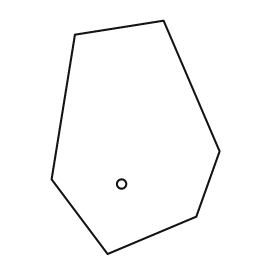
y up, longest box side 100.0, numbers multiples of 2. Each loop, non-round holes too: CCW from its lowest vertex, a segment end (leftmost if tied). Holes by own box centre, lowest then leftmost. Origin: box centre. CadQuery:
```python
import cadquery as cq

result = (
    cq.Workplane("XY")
    .moveTo(-12.0, -50.0)
    .lineTo(26.0, -34.0)
    .lineTo(36.0, -6.0)
    .lineTo(12.0, 50.0)
    .lineTo(-26.0, 44.0)
    .lineTo(-36.0, -18.0)
    .close()
    .moveTo(-6.0, -20.0)
    .circle(2.0)
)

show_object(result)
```